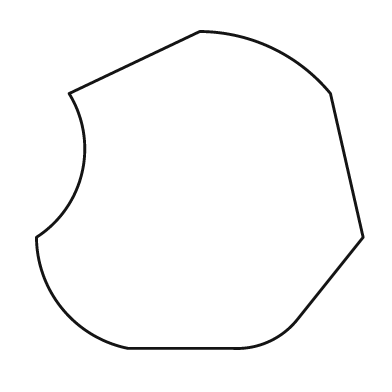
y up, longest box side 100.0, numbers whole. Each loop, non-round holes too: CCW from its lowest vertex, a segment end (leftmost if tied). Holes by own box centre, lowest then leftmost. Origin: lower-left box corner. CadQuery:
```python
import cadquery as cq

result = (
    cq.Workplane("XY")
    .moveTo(28.0, 0.0)
    .lineTo(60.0, 0.0)
    .threePointArc((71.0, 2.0), (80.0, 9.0))
    .lineTo(100.0, 34.0)
    .lineTo(90.0, 78.0)
    .threePointArc((72.0, 92.0), (50.0, 97.0))
    .lineTo(10.0, 78.0)
    .threePointArc((14.0, 54.0), (0.0, 34.0))
    .threePointArc((8.0, 12.0), (28.0, 0.0))
    .close()
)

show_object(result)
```